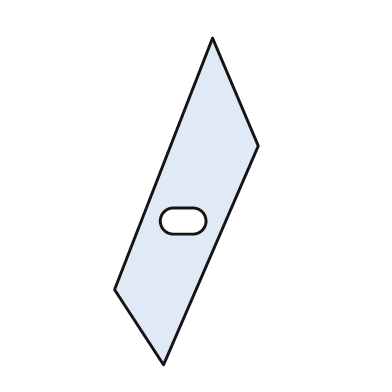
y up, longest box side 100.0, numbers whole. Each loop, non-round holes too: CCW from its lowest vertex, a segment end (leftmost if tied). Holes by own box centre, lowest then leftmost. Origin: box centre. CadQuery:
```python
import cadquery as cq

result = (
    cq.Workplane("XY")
    .moveTo(-7.0, -50.0)
    .lineTo(22.0, 17.0)
    .lineTo(8.0, 50.0)
    .lineTo(-22.0, -27.0)
    .close()
    .moveTo(-4.0, -10.0)
    .lineTo(2.0, -10.0)
    .threePointArc((6.0, -6.0), (2.0, -2.0))
    .lineTo(-4.0, -2.0)
    .threePointArc((-8.0, -6.0), (-4.0, -10.0))
    .close()
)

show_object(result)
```